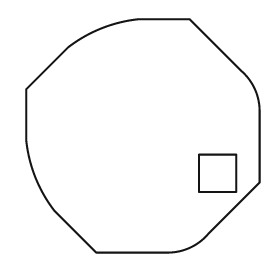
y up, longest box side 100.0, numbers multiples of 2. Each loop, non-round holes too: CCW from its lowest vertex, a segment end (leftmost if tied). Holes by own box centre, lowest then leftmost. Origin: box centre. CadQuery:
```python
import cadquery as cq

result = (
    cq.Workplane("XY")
    .moveTo(-20.0, -50.0)
    .lineTo(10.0, -50.0)
    .threePointArc((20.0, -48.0), (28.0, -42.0))
    .lineTo(50.0, -20.0)
    .lineTo(50.0, 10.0)
    .threePointArc((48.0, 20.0), (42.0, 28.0))
    .lineTo(20.0, 50.0)
    .lineTo(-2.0, 50.0)
    .threePointArc((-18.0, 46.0), (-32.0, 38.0))
    .lineTo(-50.0, 20.0)
    .lineTo(-50.0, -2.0)
    .threePointArc((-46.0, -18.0), (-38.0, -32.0))
    .close()
    .moveTo(24.0, -24.0)
    .lineTo(40.0, -24.0)
    .lineTo(40.0, -8.0)
    .lineTo(24.0, -8.0)
    .close()
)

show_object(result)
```